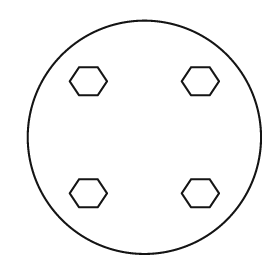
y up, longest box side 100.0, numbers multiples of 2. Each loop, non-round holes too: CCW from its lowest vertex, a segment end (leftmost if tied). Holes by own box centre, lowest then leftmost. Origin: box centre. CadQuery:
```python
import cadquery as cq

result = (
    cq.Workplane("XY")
    .moveTo(0.0, 0.0)
    .circle(50.0)
    .moveTo(-28.0, -30.0)
    .lineTo(-20.0, -30.0)
    .lineTo(-16.0, -24.0)
    .lineTo(-20.0, -18.0)
    .lineTo(-28.0, -18.0)
    .lineTo(-32.0, -24.0)
    .close()
    .moveTo(20.0, -30.0)
    .lineTo(28.0, -30.0)
    .lineTo(32.0, -24.0)
    .lineTo(28.0, -18.0)
    .lineTo(20.0, -18.0)
    .lineTo(16.0, -24.0)
    .close()
    .moveTo(-28.0, 18.0)
    .lineTo(-20.0, 18.0)
    .lineTo(-16.0, 24.0)
    .lineTo(-20.0, 30.0)
    .lineTo(-28.0, 30.0)
    .lineTo(-32.0, 24.0)
    .close()
    .moveTo(20.0, 18.0)
    .lineTo(28.0, 18.0)
    .lineTo(32.0, 24.0)
    .lineTo(28.0, 30.0)
    .lineTo(20.0, 30.0)
    .lineTo(16.0, 24.0)
    .close()
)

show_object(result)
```